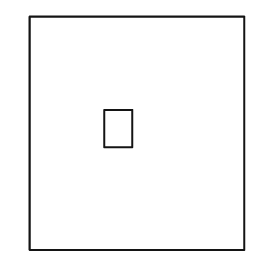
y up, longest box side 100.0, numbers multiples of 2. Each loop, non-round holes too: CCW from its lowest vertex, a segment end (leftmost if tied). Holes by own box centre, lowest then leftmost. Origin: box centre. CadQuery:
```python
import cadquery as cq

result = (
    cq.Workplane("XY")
    .moveTo(-46.0, -50.0)
    .lineTo(46.0, -50.0)
    .lineTo(46.0, 50.0)
    .lineTo(-46.0, 50.0)
    .close()
    .moveTo(-14.0, -6.0)
    .lineTo(-2.0, -6.0)
    .lineTo(-2.0, 10.0)
    .lineTo(-14.0, 10.0)
    .close()
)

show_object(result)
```